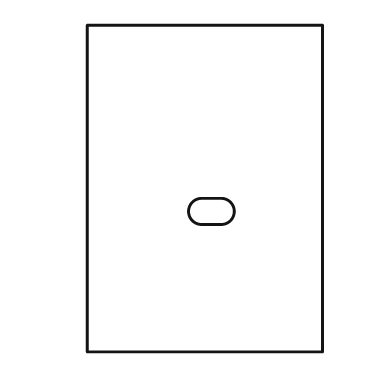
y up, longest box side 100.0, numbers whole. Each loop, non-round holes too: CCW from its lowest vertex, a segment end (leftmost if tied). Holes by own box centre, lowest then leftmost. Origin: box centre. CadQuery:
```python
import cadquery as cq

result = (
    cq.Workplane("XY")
    .moveTo(-36.0, -50.0)
    .lineTo(36.0, -50.0)
    .lineTo(36.0, 50.0)
    .lineTo(-36.0, 50.0)
    .close()
    .moveTo(-1.0, -11.0)
    .lineTo(5.0, -11.0)
    .threePointArc((9.0, -7.0), (5.0, -3.0))
    .lineTo(-1.0, -3.0)
    .threePointArc((-5.0, -7.0), (-1.0, -11.0))
    .close()
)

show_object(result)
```